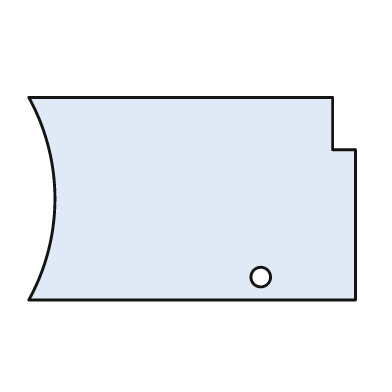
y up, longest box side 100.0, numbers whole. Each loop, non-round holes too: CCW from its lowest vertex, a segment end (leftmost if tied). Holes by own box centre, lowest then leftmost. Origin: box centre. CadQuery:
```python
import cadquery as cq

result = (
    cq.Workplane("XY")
    .moveTo(-50.0, -31.0)
    .lineTo(50.0, -31.0)
    .lineTo(50.0, 15.0)
    .lineTo(43.0, 15.0)
    .lineTo(43.0, 31.0)
    .lineTo(-50.0, 31.0)
    .threePointArc((-42.0, 0.0), (-50.0, -31.0))
    .close()
    .moveTo(21.0, -24.0)
    .circle(3.0)
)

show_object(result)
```